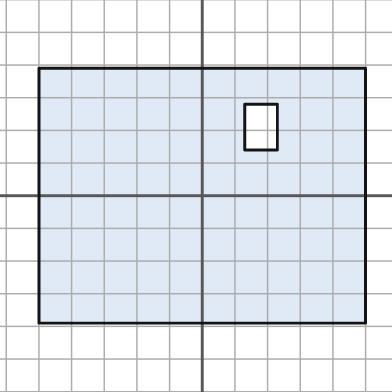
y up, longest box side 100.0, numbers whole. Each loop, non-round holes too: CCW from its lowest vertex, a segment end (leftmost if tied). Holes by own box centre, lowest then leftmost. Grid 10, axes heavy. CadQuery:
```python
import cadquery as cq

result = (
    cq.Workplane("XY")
    .moveTo(-50.0, -39.0)
    .lineTo(50.0, -39.0)
    .lineTo(50.0, 39.0)
    .lineTo(-50.0, 39.0)
    .close()
    .moveTo(13.0, 14.0)
    .lineTo(23.0, 14.0)
    .lineTo(23.0, 28.0)
    .lineTo(13.0, 28.0)
    .close()
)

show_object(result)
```